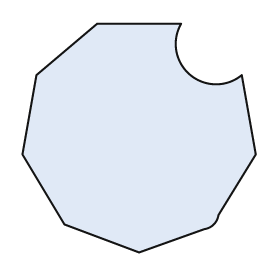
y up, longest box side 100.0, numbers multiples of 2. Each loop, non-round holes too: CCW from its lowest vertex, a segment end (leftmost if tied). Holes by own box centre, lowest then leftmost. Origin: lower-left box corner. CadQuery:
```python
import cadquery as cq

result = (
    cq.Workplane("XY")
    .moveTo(50.0, 0.0)
    .lineTo(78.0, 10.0)
    .threePointArc((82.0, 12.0), (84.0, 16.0))
    .lineTo(100.0, 42.0)
    .lineTo(94.0, 76.0)
    .threePointArc((72.0, 76.0), (68.0, 98.0))
    .lineTo(32.0, 98.0)
    .lineTo(6.0, 76.0)
    .lineTo(0.0, 42.0)
    .lineTo(18.0, 12.0)
    .close()
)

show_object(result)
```